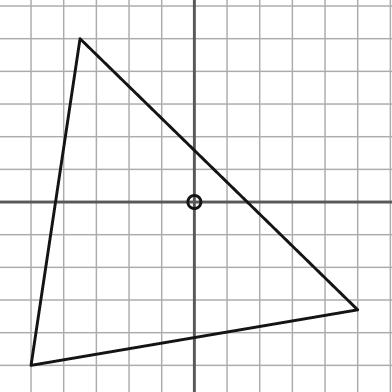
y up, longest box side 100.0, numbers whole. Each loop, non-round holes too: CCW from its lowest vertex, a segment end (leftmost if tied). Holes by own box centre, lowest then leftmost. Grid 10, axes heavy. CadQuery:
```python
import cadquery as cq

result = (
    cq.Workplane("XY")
    .moveTo(-50.0, -50.0)
    .lineTo(50.0, -33.0)
    .lineTo(-35.0, 50.0)
    .close()
    .moveTo(0.0, 0.0)
    .circle(2.0)
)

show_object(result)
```